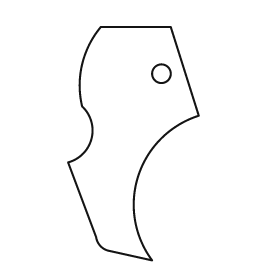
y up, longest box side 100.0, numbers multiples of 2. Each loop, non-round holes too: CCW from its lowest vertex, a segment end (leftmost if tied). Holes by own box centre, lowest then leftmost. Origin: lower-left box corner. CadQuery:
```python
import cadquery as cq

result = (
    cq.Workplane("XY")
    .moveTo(36.0, 0.0)
    .threePointArc((30.0, 36.0), (56.0, 62.0))
    .lineTo(44.0, 100.0)
    .lineTo(14.0, 100.0)
    .threePointArc((6.0, 84.0), (6.0, 66.0))
    .threePointArc((10.0, 52.0), (0.0, 42.0))
    .lineTo(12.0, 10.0)
    .threePointArc((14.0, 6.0), (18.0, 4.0))
    .close()
    .moveTo(40.0, 80.0)
    .circle(4.0)
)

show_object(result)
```